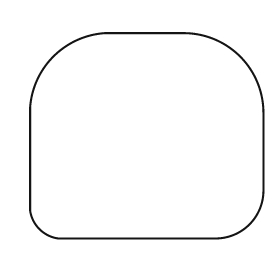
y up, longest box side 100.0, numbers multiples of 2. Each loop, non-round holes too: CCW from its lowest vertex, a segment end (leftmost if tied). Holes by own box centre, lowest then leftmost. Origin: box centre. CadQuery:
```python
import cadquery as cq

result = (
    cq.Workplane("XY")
    .moveTo(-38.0, -44.0)
    .lineTo(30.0, -44.0)
    .threePointArc((44.0, -38.0), (50.0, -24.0))
    .lineTo(50.0, 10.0)
    .threePointArc((40.0, 34.0), (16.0, 44.0))
    .lineTo(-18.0, 44.0)
    .threePointArc((-40.0, 34.0), (-50.0, 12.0))
    .lineTo(-50.0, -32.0)
    .threePointArc((-46.0, -40.0), (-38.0, -44.0))
    .close()
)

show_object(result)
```